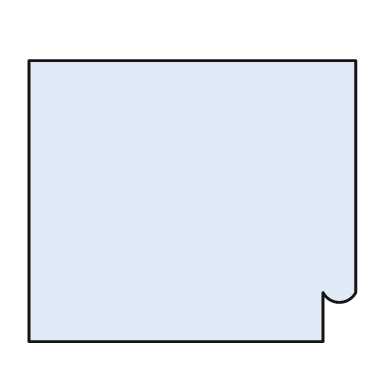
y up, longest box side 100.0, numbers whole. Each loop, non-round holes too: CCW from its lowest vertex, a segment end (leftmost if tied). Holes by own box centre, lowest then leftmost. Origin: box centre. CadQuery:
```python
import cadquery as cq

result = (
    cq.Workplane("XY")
    .moveTo(-50.0, -43.0)
    .lineTo(40.0, -43.0)
    .lineTo(40.0, -28.0)
    .threePointArc((45.0, -31.0), (50.0, -28.0))
    .lineTo(50.0, 43.0)
    .lineTo(-50.0, 43.0)
    .close()
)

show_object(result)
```